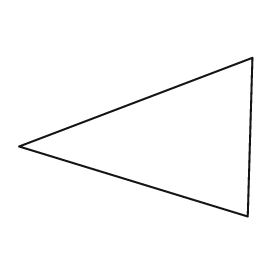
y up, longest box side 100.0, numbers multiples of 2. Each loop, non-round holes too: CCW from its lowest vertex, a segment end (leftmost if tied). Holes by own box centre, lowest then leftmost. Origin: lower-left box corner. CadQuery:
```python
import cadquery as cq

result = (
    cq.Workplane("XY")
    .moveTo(98.0, 0.0)
    .lineTo(100.0, 68.0)
    .lineTo(0.0, 30.0)
    .close()
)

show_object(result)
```